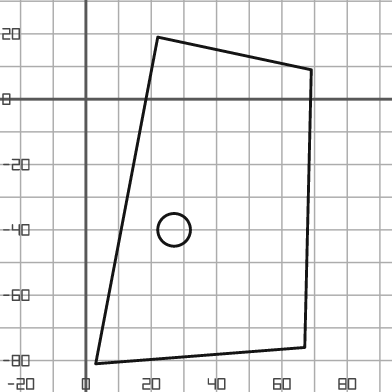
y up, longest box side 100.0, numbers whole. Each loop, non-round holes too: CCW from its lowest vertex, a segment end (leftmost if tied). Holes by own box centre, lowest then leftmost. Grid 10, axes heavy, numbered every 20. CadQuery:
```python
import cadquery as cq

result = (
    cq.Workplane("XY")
    .moveTo(3.0, -81.0)
    .lineTo(67.0, -76.0)
    .lineTo(69.0, 9.0)
    .lineTo(22.0, 19.0)
    .close()
    .moveTo(27.0, -40.0)
    .circle(5.0)
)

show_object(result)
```